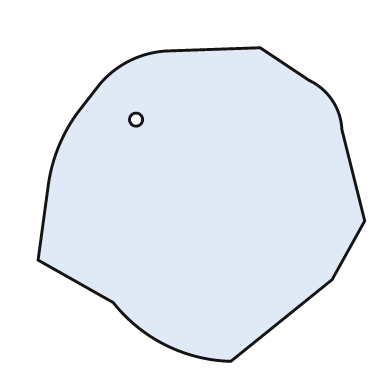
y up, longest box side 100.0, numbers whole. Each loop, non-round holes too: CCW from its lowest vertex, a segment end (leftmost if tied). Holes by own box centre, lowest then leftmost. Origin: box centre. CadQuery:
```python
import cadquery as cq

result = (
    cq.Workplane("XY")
    .moveTo(9.0, -48.0)
    .lineTo(40.0, -23.0)
    .lineTo(50.0, -5.0)
    .lineTo(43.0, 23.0)
    .threePointArc((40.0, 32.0), (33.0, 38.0))
    .lineTo(18.0, 48.0)
    .lineTo(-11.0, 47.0)
    .threePointArc((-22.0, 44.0), (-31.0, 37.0))
    .lineTo(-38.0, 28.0)
    .threePointArc((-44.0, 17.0), (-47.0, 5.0))
    .lineTo(-50.0, -17.0)
    .lineTo(-27.0, -30.0)
    .threePointArc((-11.0, -43.0), (9.0, -48.0))
    .close()
    .moveTo(-20.0, 26.0)
    .circle(2.0)
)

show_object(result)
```